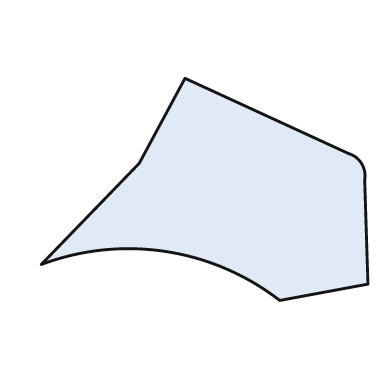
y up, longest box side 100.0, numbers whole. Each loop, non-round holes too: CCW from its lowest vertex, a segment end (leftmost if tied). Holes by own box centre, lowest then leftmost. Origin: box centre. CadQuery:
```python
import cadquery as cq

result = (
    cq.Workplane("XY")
    .moveTo(23.0, -34.0)
    .lineTo(50.0, -29.0)
    .lineTo(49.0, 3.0)
    .threePointArc((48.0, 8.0), (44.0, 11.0))
    .lineTo(-6.0, 34.0)
    .lineTo(-20.0, 8.0)
    .lineTo(-50.0, -23.0)
    .threePointArc((-12.0, -19.0), (23.0, -34.0))
    .close()
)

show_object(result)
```